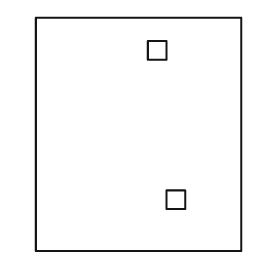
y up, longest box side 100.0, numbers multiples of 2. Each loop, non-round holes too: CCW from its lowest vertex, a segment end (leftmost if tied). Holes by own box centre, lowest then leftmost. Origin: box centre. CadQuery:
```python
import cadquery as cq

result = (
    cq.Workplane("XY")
    .moveTo(-44.0, -50.0)
    .lineTo(44.0, -50.0)
    .lineTo(44.0, 50.0)
    .lineTo(-44.0, 50.0)
    .close()
    .moveTo(12.0, -32.0)
    .lineTo(20.0, -32.0)
    .lineTo(20.0, -24.0)
    .lineTo(12.0, -24.0)
    .close()
    .moveTo(4.0, 32.0)
    .lineTo(12.0, 32.0)
    .lineTo(12.0, 40.0)
    .lineTo(4.0, 40.0)
    .close()
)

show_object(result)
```